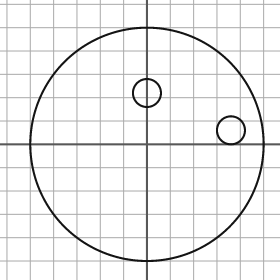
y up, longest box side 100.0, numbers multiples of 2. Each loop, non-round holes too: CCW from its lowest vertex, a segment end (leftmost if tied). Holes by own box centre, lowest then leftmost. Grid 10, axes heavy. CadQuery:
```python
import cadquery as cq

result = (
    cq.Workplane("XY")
    .moveTo(0.0, 0.0)
    .circle(50.0)
    .moveTo(36.0, 6.0)
    .circle(6.0)
    .moveTo(0.0, 22.0)
    .circle(6.0)
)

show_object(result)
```